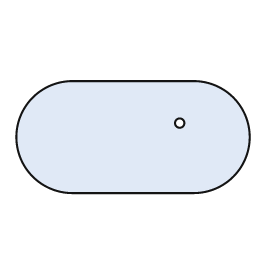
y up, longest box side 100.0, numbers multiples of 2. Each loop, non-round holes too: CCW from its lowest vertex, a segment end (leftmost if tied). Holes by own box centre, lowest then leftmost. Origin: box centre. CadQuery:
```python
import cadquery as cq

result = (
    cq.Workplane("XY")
    .moveTo(-26.0, -24.0)
    .lineTo(26.0, -24.0)
    .threePointArc((50.0, 0.0), (26.0, 24.0))
    .lineTo(-26.0, 24.0)
    .threePointArc((-50.0, 0.0), (-26.0, -24.0))
    .close()
    .moveTo(20.0, 6.0)
    .circle(2.0)
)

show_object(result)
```